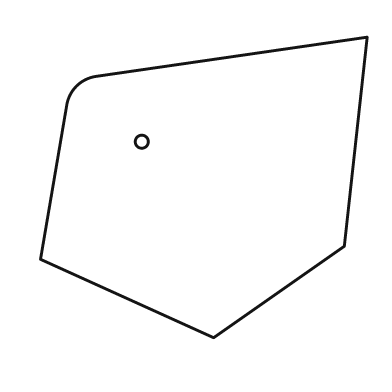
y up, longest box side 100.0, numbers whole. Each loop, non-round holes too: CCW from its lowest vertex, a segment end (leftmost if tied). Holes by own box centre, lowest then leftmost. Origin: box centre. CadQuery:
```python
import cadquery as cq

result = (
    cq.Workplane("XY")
    .moveTo(3.0, -46.0)
    .lineTo(43.0, -18.0)
    .lineTo(50.0, 46.0)
    .lineTo(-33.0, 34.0)
    .threePointArc((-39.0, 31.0), (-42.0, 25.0))
    .lineTo(-50.0, -22.0)
    .close()
    .moveTo(-19.0, 14.0)
    .circle(2.0)
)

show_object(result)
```